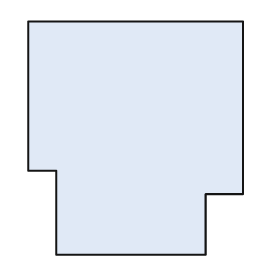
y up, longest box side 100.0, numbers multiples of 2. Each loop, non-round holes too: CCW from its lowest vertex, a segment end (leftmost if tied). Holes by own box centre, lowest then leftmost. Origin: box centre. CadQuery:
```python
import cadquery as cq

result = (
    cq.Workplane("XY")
    .moveTo(-34.0, -50.0)
    .lineTo(30.0, -50.0)
    .lineTo(30.0, -24.0)
    .lineTo(46.0, -24.0)
    .lineTo(46.0, 50.0)
    .lineTo(-46.0, 50.0)
    .lineTo(-46.0, -14.0)
    .lineTo(-34.0, -14.0)
    .close()
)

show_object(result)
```